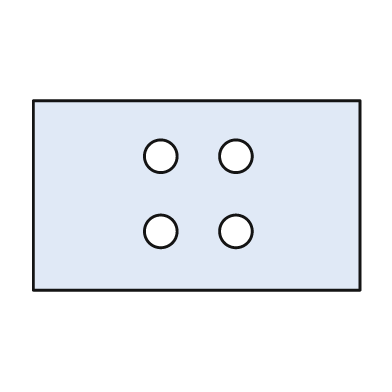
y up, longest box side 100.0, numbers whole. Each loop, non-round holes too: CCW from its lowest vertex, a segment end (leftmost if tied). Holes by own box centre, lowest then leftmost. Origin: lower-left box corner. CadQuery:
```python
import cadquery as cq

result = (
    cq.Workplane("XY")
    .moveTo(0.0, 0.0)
    .lineTo(100.0, 0.0)
    .lineTo(100.0, 58.0)
    .lineTo(0.0, 58.0)
    .close()
    .moveTo(39.0, 18.0)
    .circle(5.0)
    .moveTo(62.0, 18.0)
    .circle(5.0)
    .moveTo(39.0, 41.0)
    .circle(5.0)
    .moveTo(62.0, 41.0)
    .circle(5.0)
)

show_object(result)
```